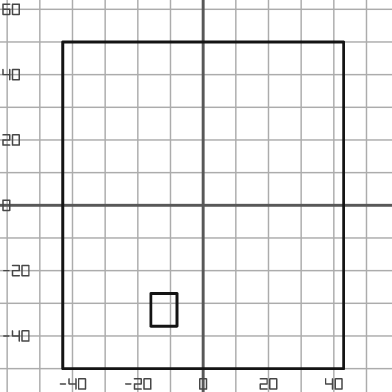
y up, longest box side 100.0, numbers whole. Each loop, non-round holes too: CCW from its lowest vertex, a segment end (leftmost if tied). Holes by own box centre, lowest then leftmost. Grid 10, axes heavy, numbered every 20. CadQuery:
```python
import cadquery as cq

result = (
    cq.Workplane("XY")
    .moveTo(-43.0, -50.0)
    .lineTo(43.0, -50.0)
    .lineTo(43.0, 50.0)
    .lineTo(-43.0, 50.0)
    .close()
    .moveTo(-16.0, -37.0)
    .lineTo(-8.0, -37.0)
    .lineTo(-8.0, -27.0)
    .lineTo(-16.0, -27.0)
    .close()
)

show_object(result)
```